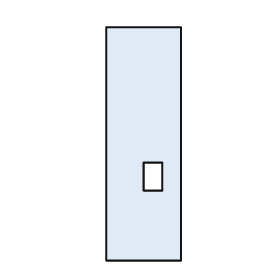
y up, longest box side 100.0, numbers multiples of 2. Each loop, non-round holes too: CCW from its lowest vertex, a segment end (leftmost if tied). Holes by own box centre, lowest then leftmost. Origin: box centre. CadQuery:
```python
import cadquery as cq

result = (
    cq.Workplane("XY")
    .moveTo(-16.0, -50.0)
    .lineTo(16.0, -50.0)
    .lineTo(16.0, 50.0)
    .lineTo(-16.0, 50.0)
    .close()
    .moveTo(0.0, -20.0)
    .lineTo(8.0, -20.0)
    .lineTo(8.0, -8.0)
    .lineTo(0.0, -8.0)
    .close()
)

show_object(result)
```